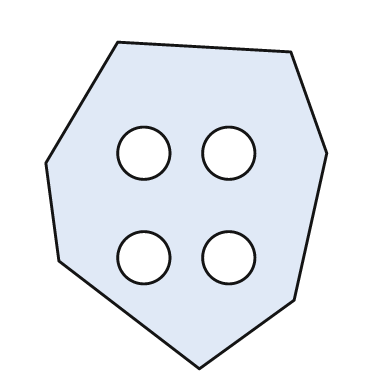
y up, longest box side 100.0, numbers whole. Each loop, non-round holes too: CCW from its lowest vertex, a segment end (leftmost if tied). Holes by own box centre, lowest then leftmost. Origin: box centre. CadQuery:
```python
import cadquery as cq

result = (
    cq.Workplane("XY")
    .moveTo(4.0, -50.0)
    .lineTo(33.0, -29.0)
    .lineTo(43.0, 16.0)
    .lineTo(32.0, 47.0)
    .lineTo(-21.0, 50.0)
    .lineTo(-43.0, 13.0)
    .lineTo(-39.0, -17.0)
    .close()
    .moveTo(-13.0, -16.0)
    .circle(8.0)
    .moveTo(13.0, -16.0)
    .circle(8.0)
    .moveTo(-13.0, 16.0)
    .circle(8.0)
    .moveTo(13.0, 16.0)
    .circle(8.0)
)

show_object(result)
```